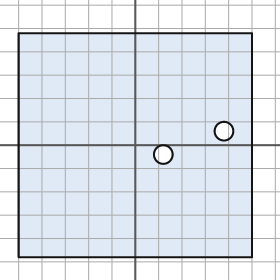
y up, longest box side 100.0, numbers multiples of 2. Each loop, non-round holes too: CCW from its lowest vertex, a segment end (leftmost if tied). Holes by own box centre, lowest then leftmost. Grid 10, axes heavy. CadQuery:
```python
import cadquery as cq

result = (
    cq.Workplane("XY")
    .moveTo(-50.0, -48.0)
    .lineTo(50.0, -48.0)
    .lineTo(50.0, 48.0)
    .lineTo(-50.0, 48.0)
    .close()
    .moveTo(12.0, -4.0)
    .circle(4.0)
    .moveTo(38.0, 6.0)
    .circle(4.0)
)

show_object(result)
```